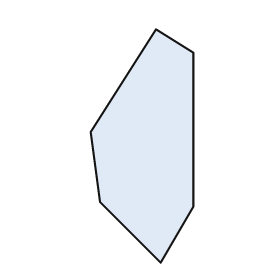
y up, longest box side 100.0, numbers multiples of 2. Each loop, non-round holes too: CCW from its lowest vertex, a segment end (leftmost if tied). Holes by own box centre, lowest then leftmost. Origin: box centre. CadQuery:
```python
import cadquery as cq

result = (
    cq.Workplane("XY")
    .moveTo(8.0, -50.0)
    .lineTo(22.0, -26.0)
    .lineTo(22.0, 40.0)
    .lineTo(6.0, 50.0)
    .lineTo(-22.0, 6.0)
    .lineTo(-18.0, -24.0)
    .close()
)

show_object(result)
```